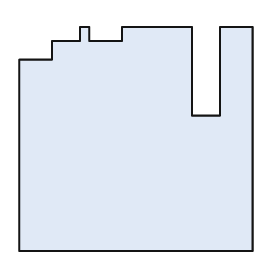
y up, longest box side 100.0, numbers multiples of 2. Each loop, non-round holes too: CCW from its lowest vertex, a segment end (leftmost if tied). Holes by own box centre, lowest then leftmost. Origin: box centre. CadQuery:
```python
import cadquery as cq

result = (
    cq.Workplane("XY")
    .moveTo(-50.0, -48.0)
    .lineTo(50.0, -48.0)
    .lineTo(50.0, 48.0)
    .lineTo(36.0, 48.0)
    .lineTo(36.0, 10.0)
    .lineTo(24.0, 10.0)
    .lineTo(24.0, 48.0)
    .lineTo(-6.0, 48.0)
    .lineTo(-6.0, 42.0)
    .lineTo(-20.0, 42.0)
    .lineTo(-20.0, 48.0)
    .lineTo(-24.0, 48.0)
    .lineTo(-24.0, 42.0)
    .lineTo(-36.0, 42.0)
    .lineTo(-36.0, 34.0)
    .lineTo(-50.0, 34.0)
    .close()
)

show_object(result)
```